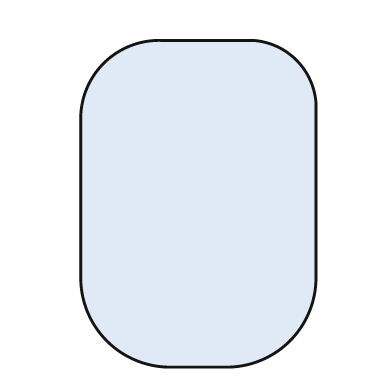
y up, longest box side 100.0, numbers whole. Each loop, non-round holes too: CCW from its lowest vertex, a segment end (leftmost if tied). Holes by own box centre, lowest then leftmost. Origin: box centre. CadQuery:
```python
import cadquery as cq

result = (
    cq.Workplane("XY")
    .moveTo(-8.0, -50.0)
    .lineTo(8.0, -50.0)
    .threePointArc((28.0, -42.0), (36.0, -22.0))
    .lineTo(36.0, 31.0)
    .threePointArc((30.0, 44.0), (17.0, 50.0))
    .lineTo(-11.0, 50.0)
    .threePointArc((-29.0, 43.0), (-36.0, 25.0))
    .lineTo(-36.0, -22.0)
    .threePointArc((-28.0, -42.0), (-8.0, -50.0))
    .close()
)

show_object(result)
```